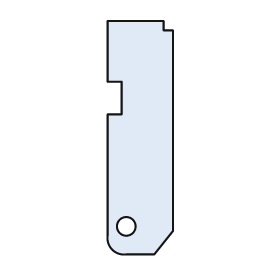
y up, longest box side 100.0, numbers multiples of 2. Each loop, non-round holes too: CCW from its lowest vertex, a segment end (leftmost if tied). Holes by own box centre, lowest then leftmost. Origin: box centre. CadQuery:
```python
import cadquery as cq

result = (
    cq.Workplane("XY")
    .moveTo(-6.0, -50.0)
    .lineTo(6.0, -50.0)
    .lineTo(14.0, -40.0)
    .lineTo(14.0, 46.0)
    .lineTo(10.0, 46.0)
    .lineTo(10.0, 50.0)
    .lineTo(-14.0, 50.0)
    .lineTo(-14.0, 24.0)
    .lineTo(-8.0, 24.0)
    .lineTo(-8.0, 10.0)
    .lineTo(-14.0, 10.0)
    .lineTo(-14.0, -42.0)
    .threePointArc((-12.0, -48.0), (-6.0, -50.0))
    .close()
    .moveTo(-6.0, -38.0)
    .circle(4.0)
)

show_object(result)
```